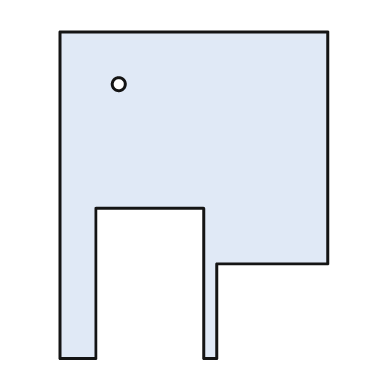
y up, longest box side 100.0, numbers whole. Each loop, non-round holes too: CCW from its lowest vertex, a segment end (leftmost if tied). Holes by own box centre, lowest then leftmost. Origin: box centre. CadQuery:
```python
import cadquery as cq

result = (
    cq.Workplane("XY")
    .moveTo(-41.0, -50.0)
    .lineTo(-30.0, -50.0)
    .lineTo(-30.0, -4.0)
    .lineTo(3.0, -4.0)
    .lineTo(3.0, -50.0)
    .lineTo(7.0, -50.0)
    .lineTo(7.0, -21.0)
    .lineTo(41.0, -21.0)
    .lineTo(41.0, 50.0)
    .lineTo(-41.0, 50.0)
    .close()
    .moveTo(-23.0, 34.0)
    .circle(2.0)
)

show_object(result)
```